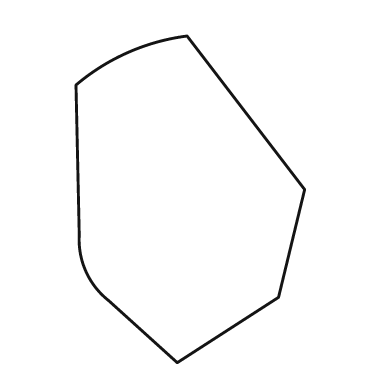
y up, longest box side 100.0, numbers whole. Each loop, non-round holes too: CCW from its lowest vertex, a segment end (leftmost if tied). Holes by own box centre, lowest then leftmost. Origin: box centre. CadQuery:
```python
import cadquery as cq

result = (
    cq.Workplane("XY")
    .moveTo(-4.0, -50.0)
    .lineTo(27.0, -30.0)
    .lineTo(35.0, 3.0)
    .lineTo(-1.0, 50.0)
    .threePointArc((-19.0, 45.0), (-35.0, 35.0))
    .lineTo(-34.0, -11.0)
    .threePointArc((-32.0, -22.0), (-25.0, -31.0))
    .close()
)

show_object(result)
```